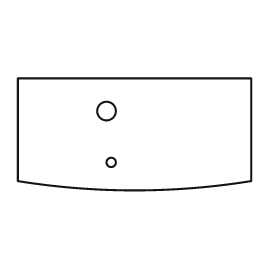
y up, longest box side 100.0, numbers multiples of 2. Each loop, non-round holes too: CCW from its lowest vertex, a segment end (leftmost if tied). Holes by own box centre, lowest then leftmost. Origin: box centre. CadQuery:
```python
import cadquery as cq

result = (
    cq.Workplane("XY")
    .moveTo(-50.0, -20.0)
    .threePointArc((0.0, -24.0), (50.0, -20.0))
    .lineTo(50.0, 24.0)
    .lineTo(-50.0, 24.0)
    .close()
    .moveTo(-10.0, -12.0)
    .circle(2.0)
    .moveTo(-12.0, 10.0)
    .circle(4.0)
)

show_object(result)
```